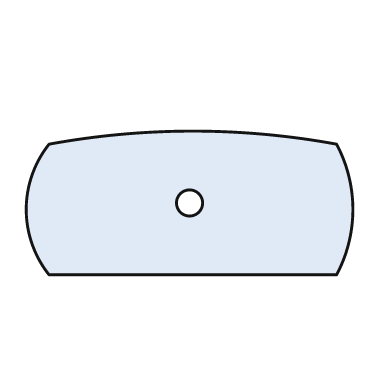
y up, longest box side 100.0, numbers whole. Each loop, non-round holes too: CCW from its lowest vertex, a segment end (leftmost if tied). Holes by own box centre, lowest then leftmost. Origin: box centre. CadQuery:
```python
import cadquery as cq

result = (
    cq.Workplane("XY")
    .moveTo(-43.0, -22.0)
    .lineTo(45.0, -22.0)
    .threePointArc((50.0, -2.0), (45.0, 18.0))
    .threePointArc((1.0, 22.0), (-43.0, 18.0))
    .threePointArc((-50.0, -2.0), (-43.0, -22.0))
    .close()
    .moveTo(0.0, 0.0)
    .circle(4.0)
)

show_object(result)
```